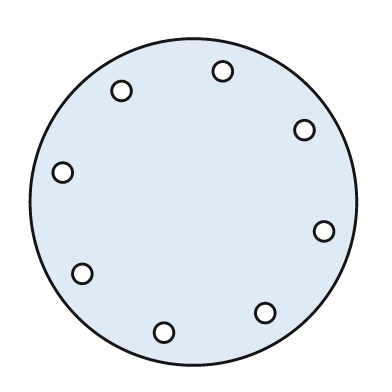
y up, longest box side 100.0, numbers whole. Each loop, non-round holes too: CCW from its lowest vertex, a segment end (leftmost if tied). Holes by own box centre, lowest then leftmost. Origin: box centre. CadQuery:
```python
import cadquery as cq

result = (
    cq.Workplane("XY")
    .moveTo(0.0, 0.0)
    .circle(50.0)
    .moveTo(-9.0, -40.0)
    .circle(3.0)
    .moveTo(22.0, -34.0)
    .circle(3.0)
    .moveTo(-34.0, -22.0)
    .circle(3.0)
    .moveTo(40.0, -9.0)
    .circle(3.0)
    .moveTo(-40.0, 9.0)
    .circle(3.0)
    .moveTo(34.0, 22.0)
    .circle(3.0)
    .moveTo(-22.0, 34.0)
    .circle(3.0)
    .moveTo(9.0, 40.0)
    .circle(3.0)
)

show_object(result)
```